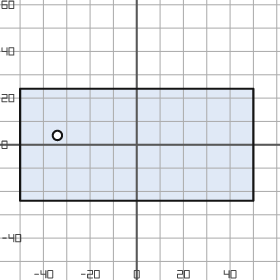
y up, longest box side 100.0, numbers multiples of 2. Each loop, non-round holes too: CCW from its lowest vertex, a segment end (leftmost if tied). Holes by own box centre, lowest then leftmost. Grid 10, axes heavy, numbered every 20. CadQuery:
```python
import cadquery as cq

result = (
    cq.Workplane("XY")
    .moveTo(-50.0, -24.0)
    .lineTo(50.0, -24.0)
    .lineTo(50.0, 24.0)
    .lineTo(-50.0, 24.0)
    .close()
    .moveTo(-34.0, 4.0)
    .circle(2.0)
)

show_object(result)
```